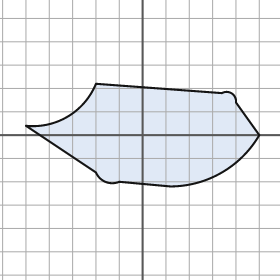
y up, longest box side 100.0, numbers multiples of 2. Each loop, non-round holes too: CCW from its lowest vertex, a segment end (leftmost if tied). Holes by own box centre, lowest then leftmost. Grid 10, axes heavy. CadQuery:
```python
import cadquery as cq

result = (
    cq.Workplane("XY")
    .moveTo(12.0, -22.0)
    .threePointArc((34.0, -16.0), (50.0, 0.0))
    .lineTo(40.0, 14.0)
    .threePointArc((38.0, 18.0), (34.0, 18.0))
    .lineTo(-20.0, 22.0)
    .threePointArc((-32.0, 8.0), (-50.0, 4.0))
    .lineTo(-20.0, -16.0)
    .threePointArc((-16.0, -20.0), (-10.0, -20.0))
    .close()
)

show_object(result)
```